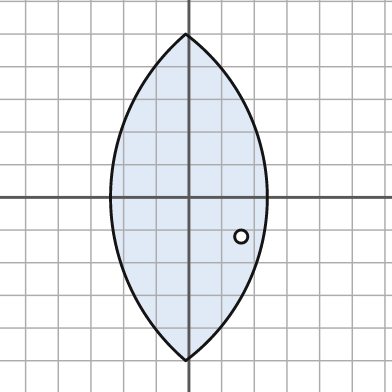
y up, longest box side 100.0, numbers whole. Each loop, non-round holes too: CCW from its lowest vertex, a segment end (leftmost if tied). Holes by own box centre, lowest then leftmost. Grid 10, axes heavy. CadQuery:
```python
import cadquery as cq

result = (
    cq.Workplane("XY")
    .moveTo(-1.0, -50.0)
    .threePointArc((24.0, 0.0), (-1.0, 50.0))
    .threePointArc((-24.0, 0.0), (-1.0, -50.0))
    .close()
    .moveTo(16.0, -12.0)
    .circle(2.0)
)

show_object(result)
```